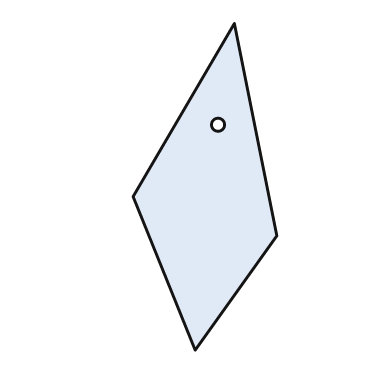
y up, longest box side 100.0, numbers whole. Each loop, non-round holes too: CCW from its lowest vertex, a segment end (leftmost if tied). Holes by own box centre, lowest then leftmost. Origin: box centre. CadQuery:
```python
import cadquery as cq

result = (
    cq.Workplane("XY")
    .moveTo(-3.0, -50.0)
    .lineTo(22.0, -15.0)
    .lineTo(9.0, 50.0)
    .lineTo(-22.0, -3.0)
    .close()
    .moveTo(4.0, 19.0)
    .circle(2.0)
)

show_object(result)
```